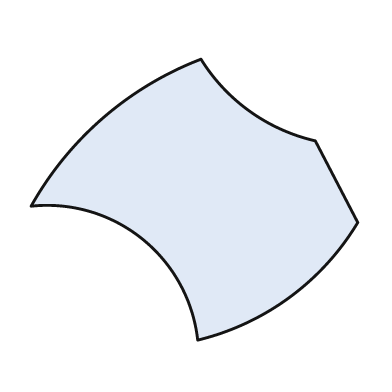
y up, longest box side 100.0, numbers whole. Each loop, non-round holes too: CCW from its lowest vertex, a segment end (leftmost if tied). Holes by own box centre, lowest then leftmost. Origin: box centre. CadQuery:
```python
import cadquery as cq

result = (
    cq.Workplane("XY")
    .moveTo(1.0, -43.0)
    .threePointArc((29.0, -30.0), (50.0, -7.0))
    .lineTo(37.0, 18.0)
    .threePointArc((17.0, 27.0), (2.0, 43.0))
    .threePointArc((-28.0, 25.0), (-50.0, -2.0))
    .threePointArc((-16.0, -12.0), (1.0, -43.0))
    .close()
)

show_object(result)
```